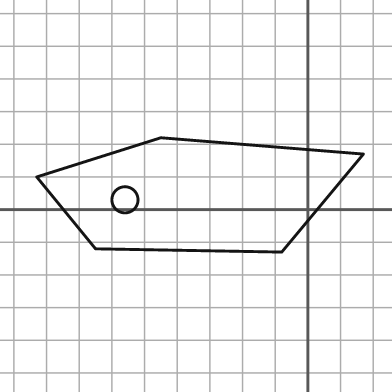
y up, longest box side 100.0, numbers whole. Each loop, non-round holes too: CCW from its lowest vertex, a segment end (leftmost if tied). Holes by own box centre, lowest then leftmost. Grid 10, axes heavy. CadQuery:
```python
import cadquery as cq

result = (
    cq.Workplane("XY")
    .moveTo(-8.0, -13.0)
    .lineTo(17.0, 17.0)
    .lineTo(-45.0, 22.0)
    .lineTo(-83.0, 10.0)
    .lineTo(-65.0, -12.0)
    .close()
    .moveTo(-56.0, 3.0)
    .circle(4.0)
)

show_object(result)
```